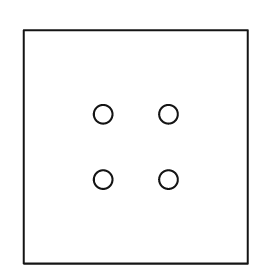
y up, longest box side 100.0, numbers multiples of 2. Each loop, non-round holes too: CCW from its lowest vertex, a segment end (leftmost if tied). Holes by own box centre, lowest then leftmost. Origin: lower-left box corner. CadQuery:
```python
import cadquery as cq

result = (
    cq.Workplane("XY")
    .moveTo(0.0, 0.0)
    .lineTo(96.0, 0.0)
    .lineTo(96.0, 100.0)
    .lineTo(0.0, 100.0)
    .close()
    .moveTo(34.0, 36.0)
    .circle(4.0)
    .moveTo(62.0, 36.0)
    .circle(4.0)
    .moveTo(34.0, 64.0)
    .circle(4.0)
    .moveTo(62.0, 64.0)
    .circle(4.0)
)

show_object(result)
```